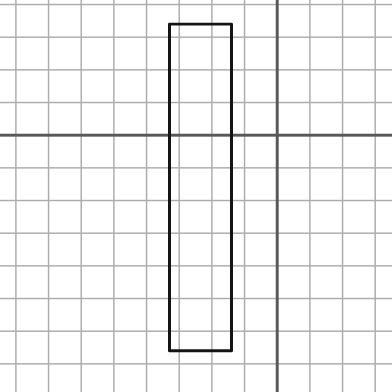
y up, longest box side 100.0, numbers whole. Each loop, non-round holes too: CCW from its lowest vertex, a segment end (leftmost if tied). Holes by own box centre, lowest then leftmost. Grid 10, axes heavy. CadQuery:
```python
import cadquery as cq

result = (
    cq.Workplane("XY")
    .moveTo(-33.0, -66.0)
    .lineTo(-14.0, -66.0)
    .lineTo(-14.0, 34.0)
    .lineTo(-33.0, 34.0)
    .close()
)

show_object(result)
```